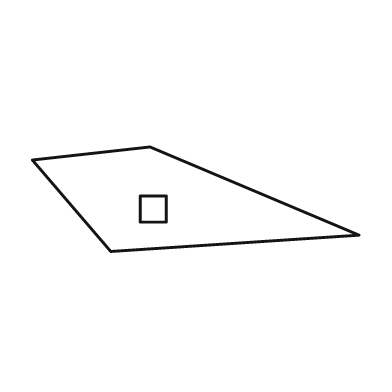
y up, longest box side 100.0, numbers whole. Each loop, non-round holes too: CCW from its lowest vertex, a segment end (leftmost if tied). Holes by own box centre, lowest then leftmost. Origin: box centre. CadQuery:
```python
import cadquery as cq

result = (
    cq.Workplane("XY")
    .moveTo(-26.0, -16.0)
    .lineTo(50.0, -11.0)
    .lineTo(-14.0, 16.0)
    .lineTo(-50.0, 12.0)
    .close()
    .moveTo(-17.0, -7.0)
    .lineTo(-9.0, -7.0)
    .lineTo(-9.0, 1.0)
    .lineTo(-17.0, 1.0)
    .close()
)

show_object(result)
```